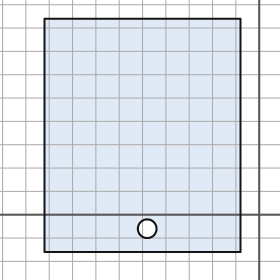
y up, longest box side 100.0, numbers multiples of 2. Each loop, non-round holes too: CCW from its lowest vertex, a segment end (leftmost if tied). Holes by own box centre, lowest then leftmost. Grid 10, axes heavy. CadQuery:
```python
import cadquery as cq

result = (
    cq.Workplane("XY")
    .moveTo(-92.0, -16.0)
    .lineTo(-8.0, -16.0)
    .lineTo(-8.0, 84.0)
    .lineTo(-92.0, 84.0)
    .close()
    .moveTo(-48.0, -6.0)
    .circle(4.0)
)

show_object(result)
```